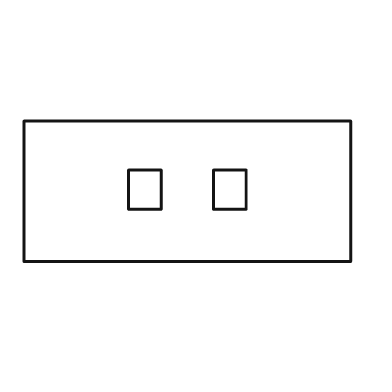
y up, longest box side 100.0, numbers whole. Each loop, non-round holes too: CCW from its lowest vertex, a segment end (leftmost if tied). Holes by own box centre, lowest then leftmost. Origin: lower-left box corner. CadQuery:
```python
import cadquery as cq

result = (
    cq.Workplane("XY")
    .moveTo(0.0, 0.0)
    .lineTo(100.0, 0.0)
    .lineTo(100.0, 43.0)
    .lineTo(0.0, 43.0)
    .close()
    .moveTo(32.0, 16.0)
    .lineTo(42.0, 16.0)
    .lineTo(42.0, 28.0)
    .lineTo(32.0, 28.0)
    .close()
    .moveTo(58.0, 16.0)
    .lineTo(68.0, 16.0)
    .lineTo(68.0, 28.0)
    .lineTo(58.0, 28.0)
    .close()
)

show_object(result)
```